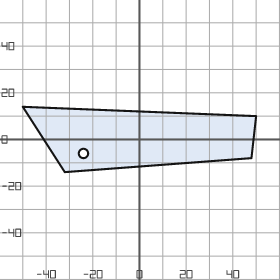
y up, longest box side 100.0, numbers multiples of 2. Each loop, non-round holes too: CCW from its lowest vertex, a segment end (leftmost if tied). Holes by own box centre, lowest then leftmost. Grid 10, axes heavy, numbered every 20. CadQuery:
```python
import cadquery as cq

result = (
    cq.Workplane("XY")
    .moveTo(-32.0, -14.0)
    .lineTo(48.0, -8.0)
    .lineTo(50.0, 10.0)
    .lineTo(-50.0, 14.0)
    .close()
    .moveTo(-24.0, -6.0)
    .circle(2.0)
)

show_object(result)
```